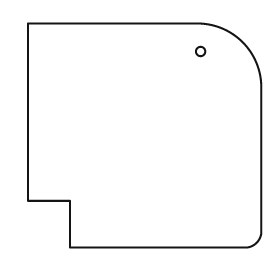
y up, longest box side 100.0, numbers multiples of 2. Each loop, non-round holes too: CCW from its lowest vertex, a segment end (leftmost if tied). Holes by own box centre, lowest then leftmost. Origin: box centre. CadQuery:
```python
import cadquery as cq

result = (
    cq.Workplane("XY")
    .moveTo(-32.0, -48.0)
    .lineTo(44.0, -48.0)
    .threePointArc((48.0, -46.0), (50.0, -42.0))
    .lineTo(50.0, 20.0)
    .threePointArc((42.0, 40.0), (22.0, 48.0))
    .lineTo(-50.0, 48.0)
    .lineTo(-50.0, -28.0)
    .lineTo(-32.0, -28.0)
    .close()
    .moveTo(24.0, 36.0)
    .circle(2.0)
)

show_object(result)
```